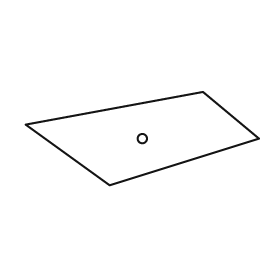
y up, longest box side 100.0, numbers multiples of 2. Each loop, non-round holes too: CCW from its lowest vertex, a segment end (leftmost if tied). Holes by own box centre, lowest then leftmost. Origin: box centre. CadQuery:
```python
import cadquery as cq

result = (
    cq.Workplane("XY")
    .moveTo(-14.0, -20.0)
    .lineTo(50.0, 0.0)
    .lineTo(26.0, 20.0)
    .lineTo(-50.0, 6.0)
    .close()
    .moveTo(0.0, 0.0)
    .circle(2.0)
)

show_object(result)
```